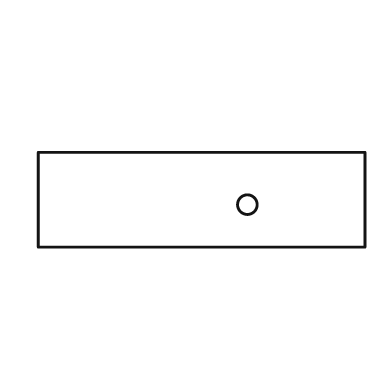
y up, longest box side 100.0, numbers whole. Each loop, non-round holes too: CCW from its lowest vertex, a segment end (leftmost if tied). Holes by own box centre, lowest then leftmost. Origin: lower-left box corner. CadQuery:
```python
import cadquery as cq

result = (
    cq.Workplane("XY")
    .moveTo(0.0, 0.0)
    .lineTo(100.0, 0.0)
    .lineTo(100.0, 29.0)
    .lineTo(0.0, 29.0)
    .close()
    .moveTo(64.0, 13.0)
    .circle(3.0)
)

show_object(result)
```